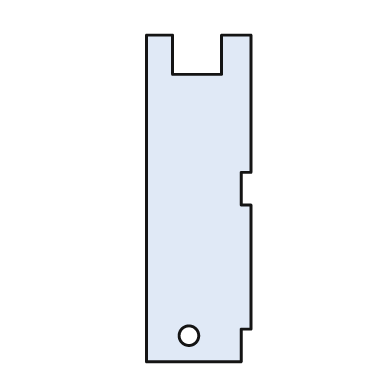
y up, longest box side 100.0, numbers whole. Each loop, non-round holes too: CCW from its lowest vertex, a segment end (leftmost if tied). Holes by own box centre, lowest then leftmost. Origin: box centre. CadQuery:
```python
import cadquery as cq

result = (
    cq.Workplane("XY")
    .moveTo(-16.0, -50.0)
    .lineTo(13.0, -50.0)
    .lineTo(13.0, -40.0)
    .lineTo(16.0, -40.0)
    .lineTo(16.0, -2.0)
    .lineTo(13.0, -2.0)
    .lineTo(13.0, 8.0)
    .lineTo(16.0, 8.0)
    .lineTo(16.0, 50.0)
    .lineTo(7.0, 50.0)
    .lineTo(7.0, 38.0)
    .lineTo(-8.0, 38.0)
    .lineTo(-8.0, 50.0)
    .lineTo(-16.0, 50.0)
    .close()
    .moveTo(-3.0, -42.0)
    .circle(3.0)
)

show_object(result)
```